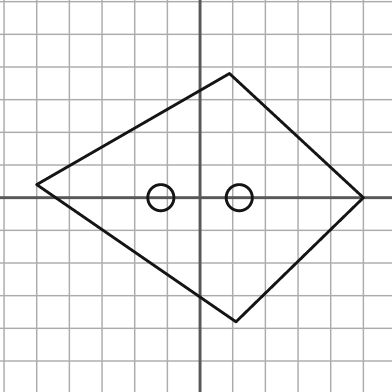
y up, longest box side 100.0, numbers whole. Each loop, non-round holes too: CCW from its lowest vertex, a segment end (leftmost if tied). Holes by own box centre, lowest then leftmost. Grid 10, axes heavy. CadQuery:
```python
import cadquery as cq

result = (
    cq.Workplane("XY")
    .moveTo(11.0, -38.0)
    .lineTo(50.0, 0.0)
    .lineTo(9.0, 38.0)
    .lineTo(-50.0, 4.0)
    .close()
    .moveTo(-12.0, 0.0)
    .circle(4.0)
    .moveTo(12.0, 0.0)
    .circle(4.0)
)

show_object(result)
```